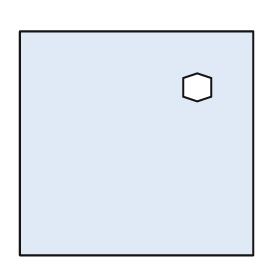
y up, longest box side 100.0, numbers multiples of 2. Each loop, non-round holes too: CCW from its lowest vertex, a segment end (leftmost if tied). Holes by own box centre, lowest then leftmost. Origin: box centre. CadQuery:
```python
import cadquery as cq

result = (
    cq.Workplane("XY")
    .moveTo(-50.0, -48.0)
    .lineTo(50.0, -48.0)
    .lineTo(50.0, 48.0)
    .lineTo(-50.0, 48.0)
    .close()
    .moveTo(26.0, 18.0)
    .lineTo(32.0, 20.0)
    .lineTo(32.0, 28.0)
    .lineTo(26.0, 30.0)
    .lineTo(20.0, 28.0)
    .lineTo(20.0, 20.0)
    .close()
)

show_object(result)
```